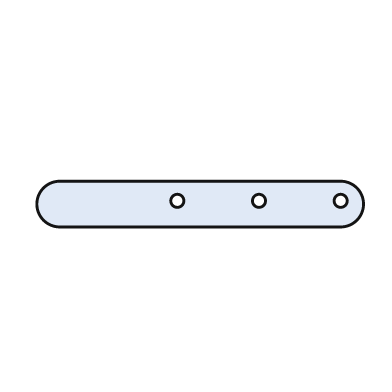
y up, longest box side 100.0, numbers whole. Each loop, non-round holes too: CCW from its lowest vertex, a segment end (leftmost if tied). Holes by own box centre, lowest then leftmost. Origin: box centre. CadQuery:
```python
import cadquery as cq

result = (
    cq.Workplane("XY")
    .moveTo(-43.0, -7.0)
    .lineTo(43.0, -7.0)
    .threePointArc((50.0, 0.0), (43.0, 7.0))
    .lineTo(-43.0, 7.0)
    .threePointArc((-50.0, 0.0), (-43.0, -7.0))
    .close()
    .moveTo(-7.0, 1.0)
    .circle(2.0)
    .moveTo(18.0, 1.0)
    .circle(2.0)
    .moveTo(43.0, 1.0)
    .circle(2.0)
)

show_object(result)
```